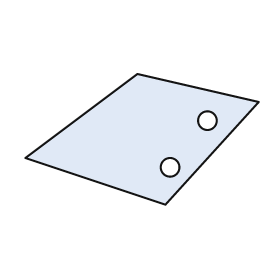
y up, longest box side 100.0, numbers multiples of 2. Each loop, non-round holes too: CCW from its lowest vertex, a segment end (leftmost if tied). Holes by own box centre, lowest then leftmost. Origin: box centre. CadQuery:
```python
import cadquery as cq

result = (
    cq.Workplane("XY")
    .moveTo(10.0, -28.0)
    .lineTo(50.0, 16.0)
    .lineTo(-2.0, 28.0)
    .lineTo(-50.0, -8.0)
    .close()
    .moveTo(12.0, -12.0)
    .circle(4.0)
    .moveTo(28.0, 8.0)
    .circle(4.0)
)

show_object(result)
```